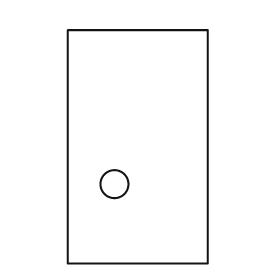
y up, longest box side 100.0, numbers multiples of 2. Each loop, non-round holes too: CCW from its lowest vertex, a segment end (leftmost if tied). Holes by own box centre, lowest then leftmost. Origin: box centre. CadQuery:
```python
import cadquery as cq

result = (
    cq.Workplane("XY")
    .moveTo(-30.0, -50.0)
    .lineTo(30.0, -50.0)
    .lineTo(30.0, 50.0)
    .lineTo(-30.0, 50.0)
    .close()
    .moveTo(-10.0, -16.0)
    .circle(6.0)
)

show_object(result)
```